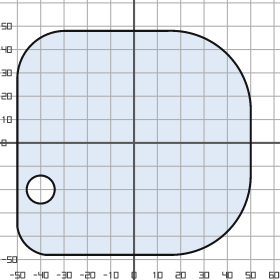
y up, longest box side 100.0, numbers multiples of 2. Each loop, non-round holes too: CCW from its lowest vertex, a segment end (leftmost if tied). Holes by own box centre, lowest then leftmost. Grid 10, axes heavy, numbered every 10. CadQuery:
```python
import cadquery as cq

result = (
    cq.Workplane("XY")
    .moveTo(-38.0, -48.0)
    .lineTo(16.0, -48.0)
    .threePointArc((40.0, -38.0), (50.0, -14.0))
    .lineTo(50.0, 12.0)
    .threePointArc((40.0, 38.0), (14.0, 48.0))
    .lineTo(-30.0, 48.0)
    .threePointArc((-44.0, 42.0), (-50.0, 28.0))
    .lineTo(-50.0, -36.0)
    .threePointArc((-46.0, -44.0), (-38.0, -48.0))
    .close()
    .moveTo(-40.0, -20.0)
    .circle(6.0)
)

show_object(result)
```